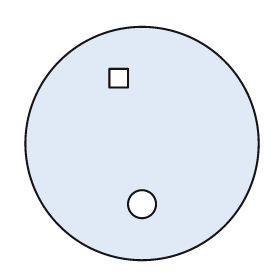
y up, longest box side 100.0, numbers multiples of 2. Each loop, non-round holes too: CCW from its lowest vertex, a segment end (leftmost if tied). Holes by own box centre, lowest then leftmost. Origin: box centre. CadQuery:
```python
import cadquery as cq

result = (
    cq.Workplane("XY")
    .moveTo(0.0, 0.0)
    .circle(50.0)
    .moveTo(0.0, -26.0)
    .circle(6.0)
    .moveTo(-14.0, 24.0)
    .lineTo(-6.0, 24.0)
    .lineTo(-6.0, 32.0)
    .lineTo(-14.0, 32.0)
    .close()
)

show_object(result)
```